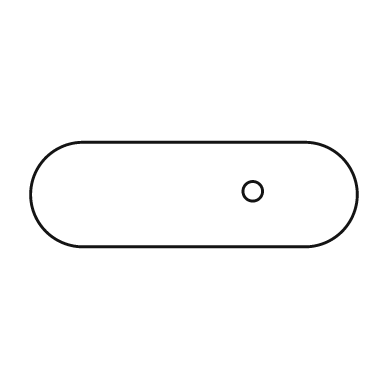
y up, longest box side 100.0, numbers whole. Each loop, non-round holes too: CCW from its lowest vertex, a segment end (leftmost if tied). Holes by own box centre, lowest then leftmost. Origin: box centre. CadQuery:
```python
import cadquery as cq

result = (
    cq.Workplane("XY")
    .moveTo(-34.0, -16.0)
    .lineTo(34.0, -16.0)
    .threePointArc((50.0, 0.0), (34.0, 16.0))
    .lineTo(-34.0, 16.0)
    .threePointArc((-50.0, 0.0), (-34.0, -16.0))
    .close()
    .moveTo(18.0, 1.0)
    .circle(3.0)
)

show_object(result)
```